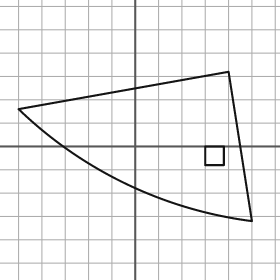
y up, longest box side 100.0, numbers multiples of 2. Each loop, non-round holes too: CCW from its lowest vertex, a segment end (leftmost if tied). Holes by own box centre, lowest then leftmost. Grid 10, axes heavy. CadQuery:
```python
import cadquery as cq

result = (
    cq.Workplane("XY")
    .moveTo(50.0, -32.0)
    .lineTo(40.0, 32.0)
    .lineTo(-50.0, 16.0)
    .threePointArc((-4.0, -16.0), (50.0, -32.0))
    .close()
    .moveTo(30.0, -8.0)
    .lineTo(38.0, -8.0)
    .lineTo(38.0, 0.0)
    .lineTo(30.0, 0.0)
    .close()
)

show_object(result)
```